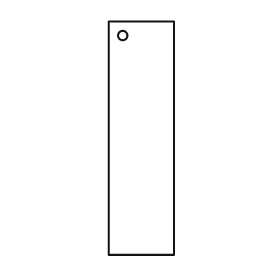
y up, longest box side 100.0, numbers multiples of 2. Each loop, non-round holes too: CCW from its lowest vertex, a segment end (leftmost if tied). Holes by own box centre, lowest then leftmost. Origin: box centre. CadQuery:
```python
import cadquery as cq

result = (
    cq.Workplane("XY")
    .moveTo(-14.0, -50.0)
    .lineTo(14.0, -50.0)
    .lineTo(14.0, 50.0)
    .lineTo(-14.0, 50.0)
    .close()
    .moveTo(-8.0, 44.0)
    .circle(2.0)
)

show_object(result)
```